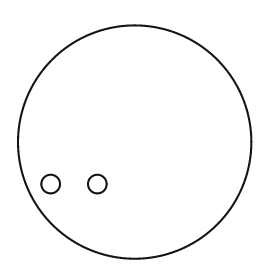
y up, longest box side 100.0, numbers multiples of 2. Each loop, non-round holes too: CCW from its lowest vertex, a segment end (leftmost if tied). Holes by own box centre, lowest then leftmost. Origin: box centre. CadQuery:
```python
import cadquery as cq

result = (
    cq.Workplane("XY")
    .moveTo(0.0, 0.0)
    .circle(50.0)
    .moveTo(-36.0, -18.0)
    .circle(4.0)
    .moveTo(-16.0, -18.0)
    .circle(4.0)
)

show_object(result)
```